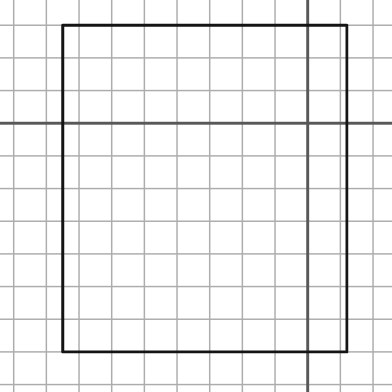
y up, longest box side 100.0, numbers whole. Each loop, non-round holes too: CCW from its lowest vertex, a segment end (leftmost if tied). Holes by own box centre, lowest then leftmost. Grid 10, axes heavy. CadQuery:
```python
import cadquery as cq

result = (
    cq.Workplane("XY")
    .moveTo(-75.0, -70.0)
    .lineTo(12.0, -70.0)
    .lineTo(12.0, 30.0)
    .lineTo(-75.0, 30.0)
    .close()
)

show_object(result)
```